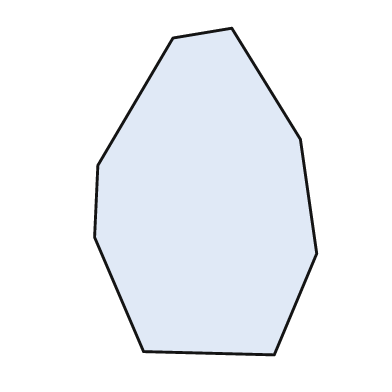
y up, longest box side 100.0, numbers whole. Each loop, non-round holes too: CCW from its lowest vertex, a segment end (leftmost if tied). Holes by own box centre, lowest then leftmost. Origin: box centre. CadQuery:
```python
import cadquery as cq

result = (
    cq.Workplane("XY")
    .moveTo(21.0, -50.0)
    .lineTo(34.0, -19.0)
    .lineTo(29.0, 16.0)
    .lineTo(8.0, 50.0)
    .lineTo(-10.0, 47.0)
    .lineTo(-33.0, 8.0)
    .lineTo(-34.0, -14.0)
    .lineTo(-19.0, -49.0)
    .close()
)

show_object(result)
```